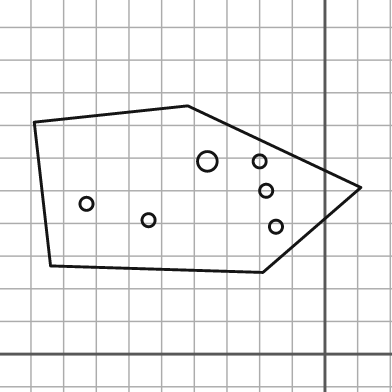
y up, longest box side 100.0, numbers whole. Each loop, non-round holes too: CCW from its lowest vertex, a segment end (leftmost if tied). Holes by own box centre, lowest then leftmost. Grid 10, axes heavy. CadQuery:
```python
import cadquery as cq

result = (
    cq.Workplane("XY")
    .moveTo(-19.0, 25.0)
    .lineTo(11.0, 51.0)
    .lineTo(-42.0, 76.0)
    .lineTo(-89.0, 71.0)
    .lineTo(-84.0, 27.0)
    .close()
    .moveTo(-15.0, 39.0)
    .circle(2.0)
    .moveTo(-54.0, 41.0)
    .circle(2.0)
    .moveTo(-73.0, 46.0)
    .circle(2.0)
    .moveTo(-18.0, 50.0)
    .circle(2.0)
    .moveTo(-36.0, 59.0)
    .circle(3.0)
    .moveTo(-20.0, 59.0)
    .circle(2.0)
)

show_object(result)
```